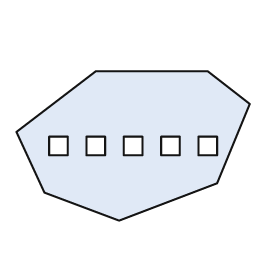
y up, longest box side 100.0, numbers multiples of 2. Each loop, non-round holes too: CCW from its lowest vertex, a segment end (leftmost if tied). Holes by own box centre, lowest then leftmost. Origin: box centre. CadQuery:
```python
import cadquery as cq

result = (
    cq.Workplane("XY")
    .moveTo(-6.0, -32.0)
    .lineTo(36.0, -16.0)
    .lineTo(50.0, 18.0)
    .lineTo(32.0, 32.0)
    .lineTo(-16.0, 32.0)
    .lineTo(-50.0, 6.0)
    .lineTo(-38.0, -20.0)
    .close()
    .moveTo(-36.0, -4.0)
    .lineTo(-28.0, -4.0)
    .lineTo(-28.0, 4.0)
    .lineTo(-36.0, 4.0)
    .close()
    .moveTo(-20.0, -4.0)
    .lineTo(-12.0, -4.0)
    .lineTo(-12.0, 4.0)
    .lineTo(-20.0, 4.0)
    .close()
    .moveTo(-4.0, -4.0)
    .lineTo(4.0, -4.0)
    .lineTo(4.0, 4.0)
    .lineTo(-4.0, 4.0)
    .close()
    .moveTo(12.0, -4.0)
    .lineTo(20.0, -4.0)
    .lineTo(20.0, 4.0)
    .lineTo(12.0, 4.0)
    .close()
    .moveTo(28.0, -4.0)
    .lineTo(36.0, -4.0)
    .lineTo(36.0, 4.0)
    .lineTo(28.0, 4.0)
    .close()
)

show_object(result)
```